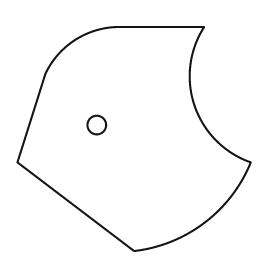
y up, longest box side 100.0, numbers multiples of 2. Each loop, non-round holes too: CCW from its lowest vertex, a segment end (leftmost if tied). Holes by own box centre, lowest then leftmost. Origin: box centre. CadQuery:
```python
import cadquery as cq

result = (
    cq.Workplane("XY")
    .moveTo(0.0, -48.0)
    .threePointArc((30.0, -36.0), (50.0, -10.0))
    .threePointArc((26.0, 14.0), (30.0, 48.0))
    .lineTo(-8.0, 48.0)
    .threePointArc((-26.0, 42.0), (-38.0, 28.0))
    .lineTo(-50.0, -10.0)
    .close()
    .moveTo(-16.0, 6.0)
    .circle(4.0)
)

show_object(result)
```